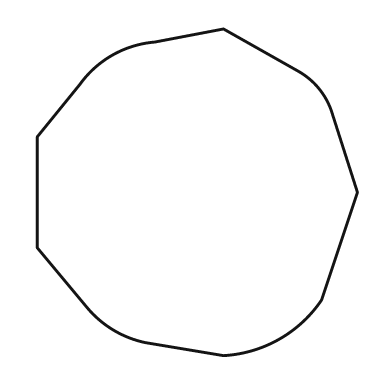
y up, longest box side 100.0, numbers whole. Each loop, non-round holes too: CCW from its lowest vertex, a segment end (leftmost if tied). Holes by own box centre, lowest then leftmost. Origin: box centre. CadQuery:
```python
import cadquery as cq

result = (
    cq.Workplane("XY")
    .moveTo(8.0, -50.0)
    .threePointArc((25.0, -45.0), (38.0, -33.0))
    .lineTo(49.0, 0.0)
    .lineTo(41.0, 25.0)
    .threePointArc((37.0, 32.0), (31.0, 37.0))
    .lineTo(8.0, 50.0)
    .lineTo(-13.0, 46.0)
    .threePointArc((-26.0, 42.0), (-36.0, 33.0))
    .lineTo(-49.0, 17.0)
    .lineTo(-49.0, -17.0)
    .lineTo(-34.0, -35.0)
    .threePointArc((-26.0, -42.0), (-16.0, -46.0))
    .close()
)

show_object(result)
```